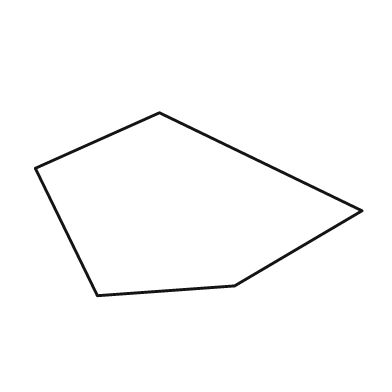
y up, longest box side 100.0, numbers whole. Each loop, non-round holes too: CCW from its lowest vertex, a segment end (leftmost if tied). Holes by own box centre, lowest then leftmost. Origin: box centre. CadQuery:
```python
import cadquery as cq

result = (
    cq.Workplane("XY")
    .moveTo(-31.0, -28.0)
    .lineTo(11.0, -25.0)
    .lineTo(50.0, -2.0)
    .lineTo(-12.0, 28.0)
    .lineTo(-50.0, 11.0)
    .close()
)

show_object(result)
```